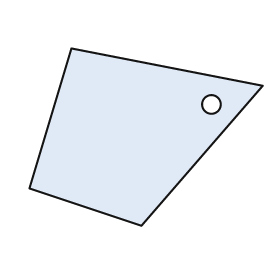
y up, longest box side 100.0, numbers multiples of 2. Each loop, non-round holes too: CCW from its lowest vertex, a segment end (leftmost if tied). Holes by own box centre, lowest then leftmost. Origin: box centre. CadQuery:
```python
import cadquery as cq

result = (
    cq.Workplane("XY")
    .moveTo(-2.0, -38.0)
    .lineTo(50.0, 22.0)
    .lineTo(-32.0, 38.0)
    .lineTo(-50.0, -22.0)
    .close()
    .moveTo(28.0, 14.0)
    .circle(4.0)
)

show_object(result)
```